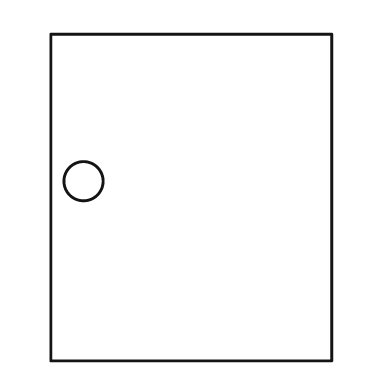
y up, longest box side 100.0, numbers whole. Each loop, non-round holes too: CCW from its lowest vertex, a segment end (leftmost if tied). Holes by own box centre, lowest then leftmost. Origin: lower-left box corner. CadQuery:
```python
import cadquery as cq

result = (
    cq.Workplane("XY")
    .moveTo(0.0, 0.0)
    .lineTo(86.0, 0.0)
    .lineTo(86.0, 100.0)
    .lineTo(0.0, 100.0)
    .close()
    .moveTo(10.0, 55.0)
    .circle(6.0)
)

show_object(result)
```